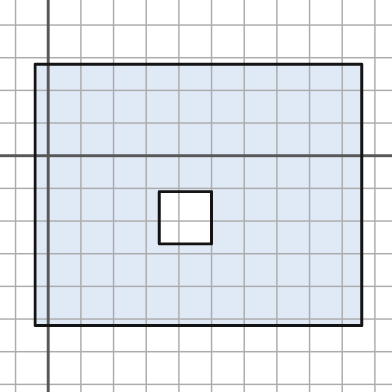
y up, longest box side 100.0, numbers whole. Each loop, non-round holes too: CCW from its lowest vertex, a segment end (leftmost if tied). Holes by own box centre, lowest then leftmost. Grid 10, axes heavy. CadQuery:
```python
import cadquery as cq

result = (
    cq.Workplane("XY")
    .moveTo(-4.0, -52.0)
    .lineTo(96.0, -52.0)
    .lineTo(96.0, 28.0)
    .lineTo(-4.0, 28.0)
    .close()
    .moveTo(34.0, -27.0)
    .lineTo(50.0, -27.0)
    .lineTo(50.0, -11.0)
    .lineTo(34.0, -11.0)
    .close()
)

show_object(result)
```